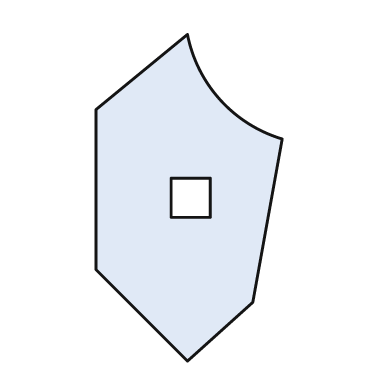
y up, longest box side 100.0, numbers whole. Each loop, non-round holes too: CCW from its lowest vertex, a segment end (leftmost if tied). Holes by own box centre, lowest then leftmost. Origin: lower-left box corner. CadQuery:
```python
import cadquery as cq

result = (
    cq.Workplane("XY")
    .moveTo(28.0, 0.0)
    .lineTo(48.0, 18.0)
    .lineTo(57.0, 68.0)
    .threePointArc((38.0, 80.0), (28.0, 100.0))
    .lineTo(0.0, 77.0)
    .lineTo(0.0, 28.0)
    .close()
    .moveTo(23.0, 44.0)
    .lineTo(35.0, 44.0)
    .lineTo(35.0, 56.0)
    .lineTo(23.0, 56.0)
    .close()
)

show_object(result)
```